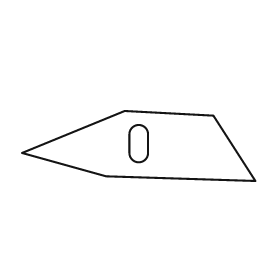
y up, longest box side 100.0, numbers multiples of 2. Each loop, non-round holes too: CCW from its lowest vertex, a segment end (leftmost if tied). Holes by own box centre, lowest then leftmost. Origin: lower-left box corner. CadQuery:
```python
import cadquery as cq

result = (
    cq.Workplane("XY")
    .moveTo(100.0, 0.0)
    .lineTo(82.0, 28.0)
    .lineTo(44.0, 30.0)
    .lineTo(0.0, 12.0)
    .lineTo(36.0, 2.0)
    .close()
    .moveTo(46.0, 12.0)
    .threePointArc((50.0, 8.0), (54.0, 12.0))
    .lineTo(54.0, 20.0)
    .threePointArc((50.0, 24.0), (46.0, 20.0))
    .close()
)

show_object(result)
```